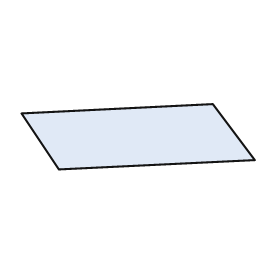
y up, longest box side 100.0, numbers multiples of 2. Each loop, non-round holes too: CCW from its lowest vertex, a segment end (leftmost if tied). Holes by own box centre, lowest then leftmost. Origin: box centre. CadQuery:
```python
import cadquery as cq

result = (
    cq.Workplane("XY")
    .moveTo(-34.0, -14.0)
    .lineTo(50.0, -10.0)
    .lineTo(32.0, 14.0)
    .lineTo(-50.0, 10.0)
    .close()
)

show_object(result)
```